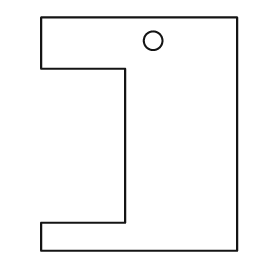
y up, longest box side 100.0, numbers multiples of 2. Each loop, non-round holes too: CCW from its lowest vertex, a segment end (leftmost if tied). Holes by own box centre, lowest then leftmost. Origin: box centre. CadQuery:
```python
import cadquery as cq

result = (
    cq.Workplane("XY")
    .moveTo(-42.0, -50.0)
    .lineTo(42.0, -50.0)
    .lineTo(42.0, 50.0)
    .lineTo(-42.0, 50.0)
    .lineTo(-42.0, 28.0)
    .lineTo(-6.0, 28.0)
    .lineTo(-6.0, -38.0)
    .lineTo(-42.0, -38.0)
    .close()
    .moveTo(6.0, 40.0)
    .circle(4.0)
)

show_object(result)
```